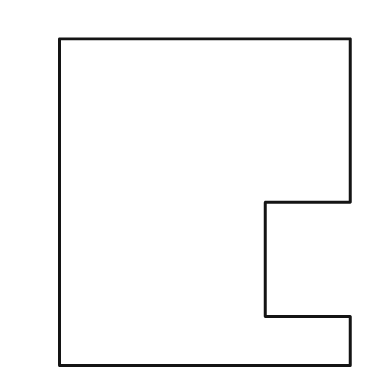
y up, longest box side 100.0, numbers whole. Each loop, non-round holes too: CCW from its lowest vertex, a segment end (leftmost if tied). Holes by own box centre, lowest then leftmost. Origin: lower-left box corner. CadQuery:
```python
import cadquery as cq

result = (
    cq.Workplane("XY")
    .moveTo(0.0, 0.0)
    .lineTo(89.0, 0.0)
    .lineTo(89.0, 15.0)
    .lineTo(63.0, 15.0)
    .lineTo(63.0, 50.0)
    .lineTo(89.0, 50.0)
    .lineTo(89.0, 100.0)
    .lineTo(0.0, 100.0)
    .close()
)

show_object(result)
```